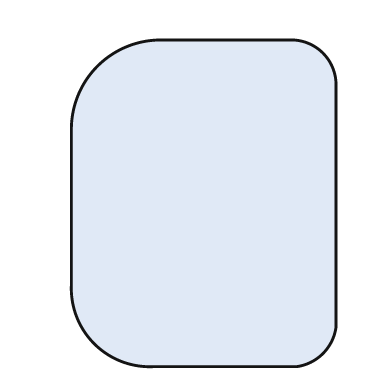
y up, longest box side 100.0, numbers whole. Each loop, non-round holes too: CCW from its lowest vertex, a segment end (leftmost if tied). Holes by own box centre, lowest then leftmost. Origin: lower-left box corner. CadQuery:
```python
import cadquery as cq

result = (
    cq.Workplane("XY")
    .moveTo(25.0, 0.0)
    .lineTo(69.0, 0.0)
    .threePointArc((77.0, 4.0), (81.0, 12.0))
    .lineTo(81.0, 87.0)
    .threePointArc((77.0, 96.0), (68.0, 100.0))
    .lineTo(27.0, 100.0)
    .threePointArc((8.0, 92.0), (0.0, 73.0))
    .lineTo(0.0, 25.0)
    .threePointArc((7.0, 7.0), (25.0, 0.0))
    .close()
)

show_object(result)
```